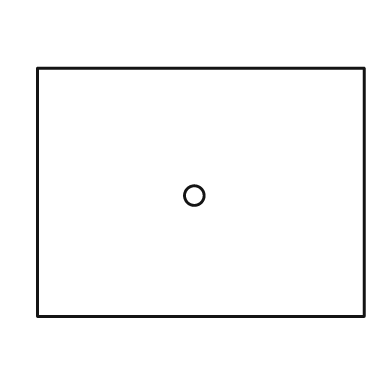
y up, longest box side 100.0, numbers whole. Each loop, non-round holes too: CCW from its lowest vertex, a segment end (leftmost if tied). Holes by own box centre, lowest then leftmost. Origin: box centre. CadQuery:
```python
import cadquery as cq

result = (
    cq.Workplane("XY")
    .moveTo(-50.0, -38.0)
    .lineTo(50.0, -38.0)
    .lineTo(50.0, 38.0)
    .lineTo(-50.0, 38.0)
    .close()
    .moveTo(-2.0, -1.0)
    .circle(3.0)
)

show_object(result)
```